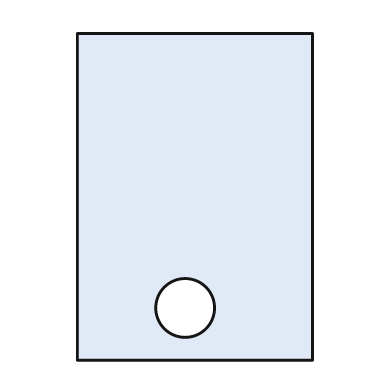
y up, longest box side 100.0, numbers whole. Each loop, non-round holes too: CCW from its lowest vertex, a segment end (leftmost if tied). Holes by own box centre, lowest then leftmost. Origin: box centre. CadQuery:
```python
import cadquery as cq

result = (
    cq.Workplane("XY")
    .moveTo(-36.0, -50.0)
    .lineTo(36.0, -50.0)
    .lineTo(36.0, 50.0)
    .lineTo(-36.0, 50.0)
    .close()
    .moveTo(-3.0, -34.0)
    .circle(9.0)
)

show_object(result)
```